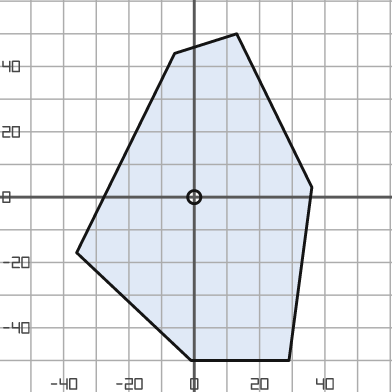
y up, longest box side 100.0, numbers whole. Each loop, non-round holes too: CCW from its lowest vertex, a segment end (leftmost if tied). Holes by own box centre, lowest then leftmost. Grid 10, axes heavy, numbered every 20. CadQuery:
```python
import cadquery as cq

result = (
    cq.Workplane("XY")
    .moveTo(-1.0, -50.0)
    .lineTo(29.0, -50.0)
    .lineTo(36.0, 3.0)
    .lineTo(13.0, 50.0)
    .lineTo(-6.0, 44.0)
    .lineTo(-36.0, -17.0)
    .close()
    .moveTo(0.0, 0.0)
    .circle(2.0)
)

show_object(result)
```